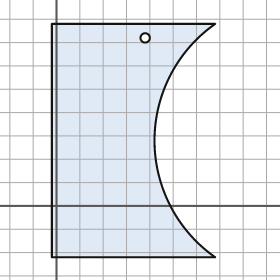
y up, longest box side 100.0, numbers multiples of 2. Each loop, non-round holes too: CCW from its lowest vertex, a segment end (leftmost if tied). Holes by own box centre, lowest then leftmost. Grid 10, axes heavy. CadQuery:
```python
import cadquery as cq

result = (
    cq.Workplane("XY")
    .moveTo(-2.0, -22.0)
    .lineTo(68.0, -22.0)
    .threePointArc((42.0, 28.0), (68.0, 78.0))
    .lineTo(-2.0, 78.0)
    .close()
    .moveTo(38.0, 72.0)
    .circle(2.0)
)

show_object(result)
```